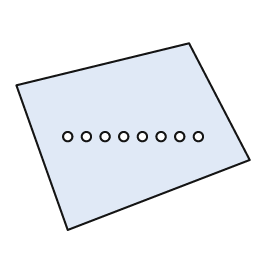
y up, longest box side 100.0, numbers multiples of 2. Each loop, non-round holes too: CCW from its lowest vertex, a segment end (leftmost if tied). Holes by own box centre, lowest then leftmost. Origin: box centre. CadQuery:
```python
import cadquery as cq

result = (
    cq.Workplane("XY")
    .moveTo(-28.0, -40.0)
    .lineTo(50.0, -10.0)
    .lineTo(24.0, 40.0)
    .lineTo(-50.0, 22.0)
    .close()
    .moveTo(-28.0, 0.0)
    .circle(2.0)
    .moveTo(-20.0, 0.0)
    .circle(2.0)
    .moveTo(-12.0, 0.0)
    .circle(2.0)
    .moveTo(-4.0, 0.0)
    .circle(2.0)
    .moveTo(4.0, 0.0)
    .circle(2.0)
    .moveTo(12.0, 0.0)
    .circle(2.0)
    .moveTo(20.0, 0.0)
    .circle(2.0)
    .moveTo(28.0, 0.0)
    .circle(2.0)
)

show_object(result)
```